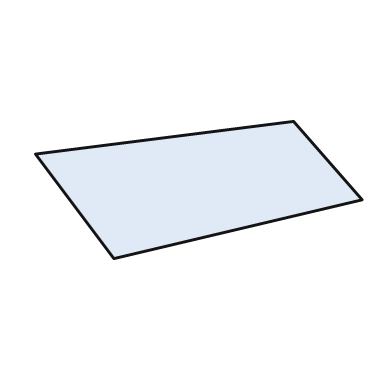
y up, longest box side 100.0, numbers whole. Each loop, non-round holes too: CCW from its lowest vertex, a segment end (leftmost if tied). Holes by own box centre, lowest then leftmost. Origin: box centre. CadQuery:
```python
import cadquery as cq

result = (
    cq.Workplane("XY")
    .moveTo(-26.0, -21.0)
    .lineTo(50.0, -3.0)
    .lineTo(29.0, 21.0)
    .lineTo(-50.0, 11.0)
    .close()
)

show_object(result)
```